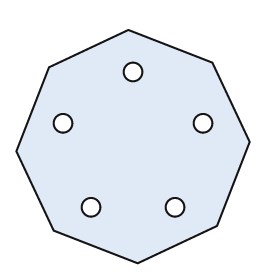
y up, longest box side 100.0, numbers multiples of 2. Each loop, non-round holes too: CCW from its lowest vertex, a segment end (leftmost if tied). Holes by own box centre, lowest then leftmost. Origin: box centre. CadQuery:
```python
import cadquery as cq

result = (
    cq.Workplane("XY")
    .moveTo(2.0, -50.0)
    .lineTo(36.0, -34.0)
    .lineTo(50.0, 2.0)
    .lineTo(34.0, 36.0)
    .lineTo(-2.0, 50.0)
    .lineTo(-36.0, 34.0)
    .lineTo(-50.0, -2.0)
    .lineTo(-34.0, -36.0)
    .close()
    .moveTo(-18.0, -26.0)
    .circle(4.0)
    .moveTo(18.0, -26.0)
    .circle(4.0)
    .moveTo(-30.0, 10.0)
    .circle(4.0)
    .moveTo(30.0, 10.0)
    .circle(4.0)
    .moveTo(0.0, 32.0)
    .circle(4.0)
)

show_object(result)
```